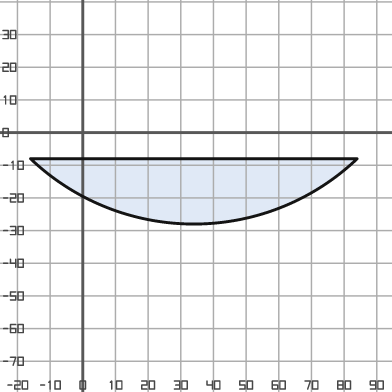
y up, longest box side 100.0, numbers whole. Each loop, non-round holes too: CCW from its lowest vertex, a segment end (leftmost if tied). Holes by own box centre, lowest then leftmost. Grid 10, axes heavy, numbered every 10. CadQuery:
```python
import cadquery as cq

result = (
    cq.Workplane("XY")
    .moveTo(-16.0, -8.0)
    .threePointArc((34.0, -28.0), (84.0, -8.0))
    .close()
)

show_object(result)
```